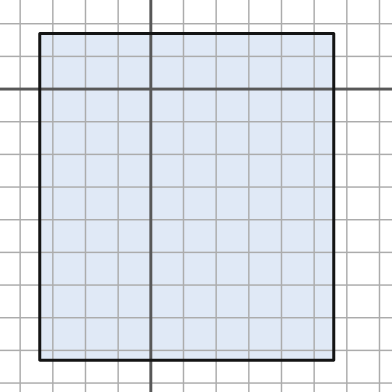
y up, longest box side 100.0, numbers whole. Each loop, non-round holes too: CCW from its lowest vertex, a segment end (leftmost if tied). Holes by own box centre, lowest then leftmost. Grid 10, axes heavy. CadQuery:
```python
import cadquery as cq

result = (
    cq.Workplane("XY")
    .moveTo(-34.0, -83.0)
    .lineTo(56.0, -83.0)
    .lineTo(56.0, 17.0)
    .lineTo(-34.0, 17.0)
    .close()
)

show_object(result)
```